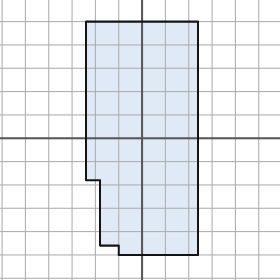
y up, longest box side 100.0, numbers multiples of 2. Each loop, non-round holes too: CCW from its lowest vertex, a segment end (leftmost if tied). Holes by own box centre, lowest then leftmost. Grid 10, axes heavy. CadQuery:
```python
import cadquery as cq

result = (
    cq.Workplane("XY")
    .moveTo(-10.0, -50.0)
    .lineTo(24.0, -50.0)
    .lineTo(24.0, 50.0)
    .lineTo(-24.0, 50.0)
    .lineTo(-24.0, -18.0)
    .lineTo(-18.0, -18.0)
    .lineTo(-18.0, -46.0)
    .lineTo(-10.0, -46.0)
    .close()
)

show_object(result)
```